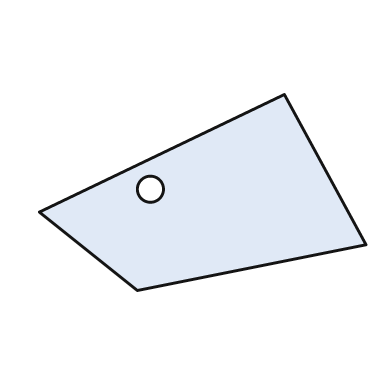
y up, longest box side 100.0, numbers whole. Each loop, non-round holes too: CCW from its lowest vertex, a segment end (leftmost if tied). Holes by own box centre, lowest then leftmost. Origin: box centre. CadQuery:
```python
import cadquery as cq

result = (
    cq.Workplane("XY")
    .moveTo(-20.0, -30.0)
    .lineTo(50.0, -16.0)
    .lineTo(25.0, 30.0)
    .lineTo(-50.0, -6.0)
    .close()
    .moveTo(-16.0, 1.0)
    .circle(4.0)
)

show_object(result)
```